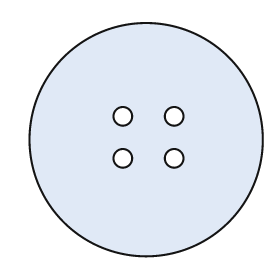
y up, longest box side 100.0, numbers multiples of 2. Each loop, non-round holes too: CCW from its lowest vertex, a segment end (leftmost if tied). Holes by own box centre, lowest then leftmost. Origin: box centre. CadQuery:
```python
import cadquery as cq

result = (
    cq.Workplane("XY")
    .moveTo(0.0, 0.0)
    .circle(50.0)
    .moveTo(-10.0, -8.0)
    .circle(4.0)
    .moveTo(12.0, -8.0)
    .circle(4.0)
    .moveTo(-10.0, 10.0)
    .circle(4.0)
    .moveTo(12.0, 10.0)
    .circle(4.0)
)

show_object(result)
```